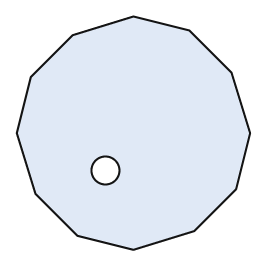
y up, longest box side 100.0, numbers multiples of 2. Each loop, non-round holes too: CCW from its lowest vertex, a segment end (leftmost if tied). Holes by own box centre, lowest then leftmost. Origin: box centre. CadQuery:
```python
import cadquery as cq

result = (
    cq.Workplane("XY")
    .moveTo(0.0, -50.0)
    .lineTo(26.0, -42.0)
    .lineTo(44.0, -24.0)
    .lineTo(50.0, 0.0)
    .lineTo(42.0, 26.0)
    .lineTo(24.0, 44.0)
    .lineTo(0.0, 50.0)
    .lineTo(-26.0, 42.0)
    .lineTo(-44.0, 24.0)
    .lineTo(-50.0, 0.0)
    .lineTo(-42.0, -26.0)
    .lineTo(-24.0, -44.0)
    .close()
    .moveTo(-12.0, -16.0)
    .circle(6.0)
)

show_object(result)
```